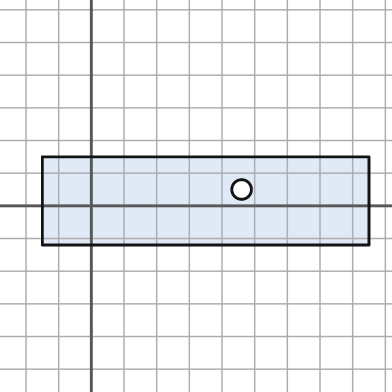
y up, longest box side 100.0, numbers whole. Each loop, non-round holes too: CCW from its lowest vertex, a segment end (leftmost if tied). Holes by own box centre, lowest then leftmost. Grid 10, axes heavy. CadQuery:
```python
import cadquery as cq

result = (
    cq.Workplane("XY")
    .moveTo(-15.0, -12.0)
    .lineTo(85.0, -12.0)
    .lineTo(85.0, 15.0)
    .lineTo(-15.0, 15.0)
    .close()
    .moveTo(46.0, 5.0)
    .circle(3.0)
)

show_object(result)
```